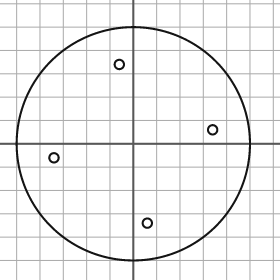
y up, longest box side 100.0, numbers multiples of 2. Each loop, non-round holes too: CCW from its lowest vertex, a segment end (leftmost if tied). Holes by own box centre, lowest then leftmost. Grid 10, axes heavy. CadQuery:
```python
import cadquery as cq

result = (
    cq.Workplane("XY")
    .moveTo(0.0, 0.0)
    .circle(50.0)
    .moveTo(6.0, -34.0)
    .circle(2.0)
    .moveTo(-34.0, -6.0)
    .circle(2.0)
    .moveTo(34.0, 6.0)
    .circle(2.0)
    .moveTo(-6.0, 34.0)
    .circle(2.0)
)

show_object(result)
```